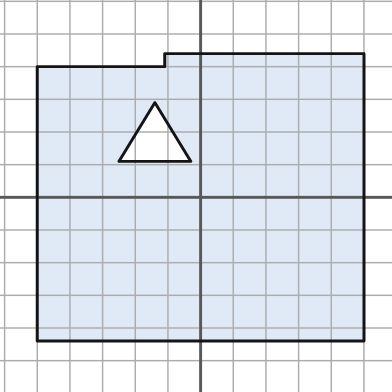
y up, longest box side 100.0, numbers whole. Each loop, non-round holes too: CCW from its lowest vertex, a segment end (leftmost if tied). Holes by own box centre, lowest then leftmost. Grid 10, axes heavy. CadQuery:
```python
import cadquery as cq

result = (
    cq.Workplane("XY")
    .moveTo(-50.0, -44.0)
    .lineTo(50.0, -44.0)
    .lineTo(50.0, 44.0)
    .lineTo(-11.0, 44.0)
    .lineTo(-11.0, 40.0)
    .lineTo(-50.0, 40.0)
    .close()
    .moveTo(-25.0, 11.0)
    .lineTo(-3.0, 11.0)
    .lineTo(-14.0, 29.0)
    .close()
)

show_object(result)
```